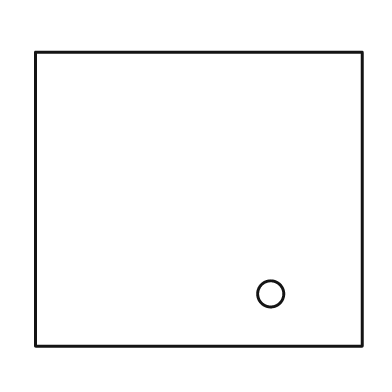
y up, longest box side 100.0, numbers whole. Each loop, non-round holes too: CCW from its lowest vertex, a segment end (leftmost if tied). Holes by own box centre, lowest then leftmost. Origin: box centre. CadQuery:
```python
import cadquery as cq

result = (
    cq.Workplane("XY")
    .moveTo(-50.0, -45.0)
    .lineTo(50.0, -45.0)
    .lineTo(50.0, 45.0)
    .lineTo(-50.0, 45.0)
    .close()
    .moveTo(22.0, -29.0)
    .circle(4.0)
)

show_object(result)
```